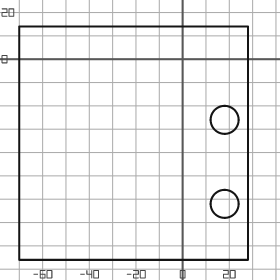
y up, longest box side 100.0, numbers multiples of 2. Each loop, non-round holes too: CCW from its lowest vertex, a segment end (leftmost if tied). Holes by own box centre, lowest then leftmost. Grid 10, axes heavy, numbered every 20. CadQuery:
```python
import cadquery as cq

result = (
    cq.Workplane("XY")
    .moveTo(-70.0, -86.0)
    .lineTo(28.0, -86.0)
    .lineTo(28.0, 14.0)
    .lineTo(-70.0, 14.0)
    .close()
    .moveTo(18.0, -62.0)
    .circle(6.0)
    .moveTo(18.0, -26.0)
    .circle(6.0)
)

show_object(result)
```